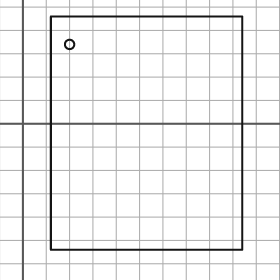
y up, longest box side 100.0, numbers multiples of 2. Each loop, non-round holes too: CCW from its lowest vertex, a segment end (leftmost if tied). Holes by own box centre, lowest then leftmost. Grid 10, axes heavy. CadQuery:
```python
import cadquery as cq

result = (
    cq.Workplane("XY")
    .moveTo(12.0, -54.0)
    .lineTo(94.0, -54.0)
    .lineTo(94.0, 46.0)
    .lineTo(12.0, 46.0)
    .close()
    .moveTo(20.0, 34.0)
    .circle(2.0)
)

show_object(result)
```